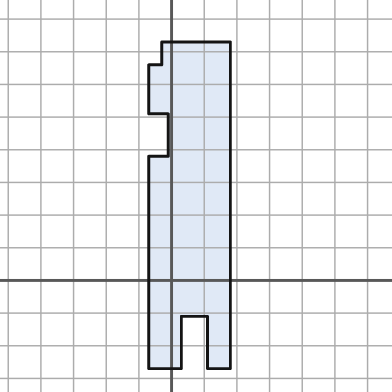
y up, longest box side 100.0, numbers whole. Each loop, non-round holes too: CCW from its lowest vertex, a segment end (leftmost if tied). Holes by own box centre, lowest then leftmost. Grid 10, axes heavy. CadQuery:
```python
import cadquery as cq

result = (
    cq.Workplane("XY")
    .moveTo(-7.0, -27.0)
    .lineTo(3.0, -27.0)
    .lineTo(3.0, -11.0)
    .lineTo(11.0, -11.0)
    .lineTo(11.0, -27.0)
    .lineTo(18.0, -27.0)
    .lineTo(18.0, 73.0)
    .lineTo(-3.0, 73.0)
    .lineTo(-3.0, 66.0)
    .lineTo(-7.0, 66.0)
    .lineTo(-7.0, 51.0)
    .lineTo(-1.0, 51.0)
    .lineTo(-1.0, 38.0)
    .lineTo(-7.0, 38.0)
    .close()
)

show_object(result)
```